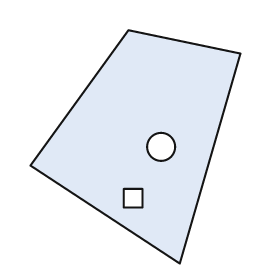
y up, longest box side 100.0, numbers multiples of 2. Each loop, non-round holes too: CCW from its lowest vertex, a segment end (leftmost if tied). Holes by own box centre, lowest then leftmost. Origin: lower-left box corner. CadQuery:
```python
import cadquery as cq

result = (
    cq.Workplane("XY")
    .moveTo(64.0, 0.0)
    .lineTo(90.0, 90.0)
    .lineTo(42.0, 100.0)
    .lineTo(0.0, 42.0)
    .close()
    .moveTo(40.0, 24.0)
    .lineTo(48.0, 24.0)
    .lineTo(48.0, 32.0)
    .lineTo(40.0, 32.0)
    .close()
    .moveTo(56.0, 50.0)
    .circle(6.0)
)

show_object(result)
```